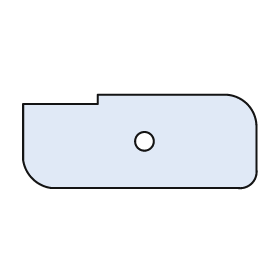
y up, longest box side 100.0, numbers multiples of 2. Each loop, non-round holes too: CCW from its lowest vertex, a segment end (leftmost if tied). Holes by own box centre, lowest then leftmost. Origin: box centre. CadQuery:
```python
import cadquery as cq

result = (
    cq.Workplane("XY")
    .moveTo(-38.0, -20.0)
    .lineTo(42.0, -20.0)
    .threePointArc((48.0, -18.0), (50.0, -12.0))
    .lineTo(50.0, 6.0)
    .threePointArc((46.0, 16.0), (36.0, 20.0))
    .lineTo(-18.0, 20.0)
    .lineTo(-18.0, 16.0)
    .lineTo(-50.0, 16.0)
    .lineTo(-50.0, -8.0)
    .threePointArc((-46.0, -16.0), (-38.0, -20.0))
    .close()
    .moveTo(2.0, 0.0)
    .circle(4.0)
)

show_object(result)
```